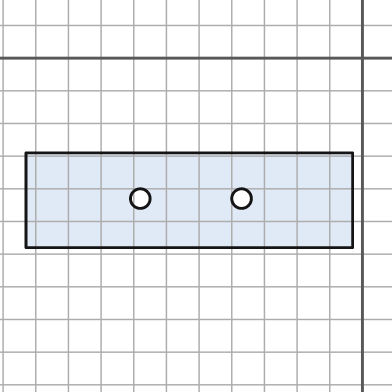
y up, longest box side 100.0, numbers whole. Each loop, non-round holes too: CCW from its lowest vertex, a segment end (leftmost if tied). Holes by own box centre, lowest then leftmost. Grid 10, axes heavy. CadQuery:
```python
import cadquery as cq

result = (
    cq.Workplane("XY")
    .moveTo(-103.0, -58.0)
    .lineTo(-3.0, -58.0)
    .lineTo(-3.0, -29.0)
    .lineTo(-103.0, -29.0)
    .close()
    .moveTo(-68.0, -43.0)
    .circle(3.0)
    .moveTo(-37.0, -43.0)
    .circle(3.0)
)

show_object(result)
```